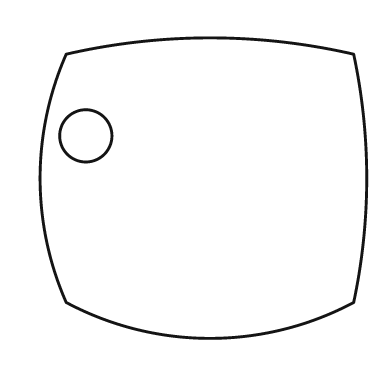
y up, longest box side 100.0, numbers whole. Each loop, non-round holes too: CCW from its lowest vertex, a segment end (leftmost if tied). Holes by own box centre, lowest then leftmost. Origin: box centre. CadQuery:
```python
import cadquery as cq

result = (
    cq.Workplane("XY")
    .moveTo(-42.0, -35.0)
    .threePointArc((2.0, -46.0), (46.0, -35.0))
    .threePointArc((50.0, 3.0), (46.0, 41.0))
    .threePointArc((2.0, 46.0), (-42.0, 41.0))
    .threePointArc((-50.0, 3.0), (-42.0, -35.0))
    .close()
    .moveTo(-36.0, 16.0)
    .circle(8.0)
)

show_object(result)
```